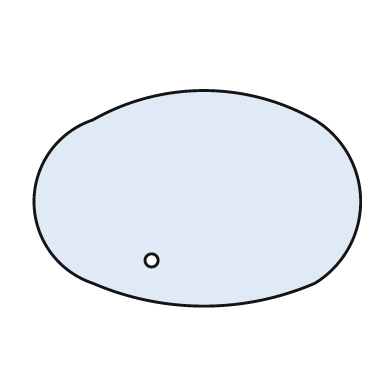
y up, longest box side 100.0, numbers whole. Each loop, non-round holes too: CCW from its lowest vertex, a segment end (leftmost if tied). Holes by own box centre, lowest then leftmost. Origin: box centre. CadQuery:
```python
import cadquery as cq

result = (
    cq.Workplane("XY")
    .moveTo(-32.0, -26.0)
    .threePointArc((2.0, -33.0), (36.0, -26.0))
    .threePointArc((50.0, -1.0), (36.0, 24.0))
    .threePointArc((2.0, 33.0), (-32.0, 24.0))
    .threePointArc((-50.0, -1.0), (-32.0, -26.0))
    .close()
    .moveTo(-14.0, -19.0)
    .circle(2.0)
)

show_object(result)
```